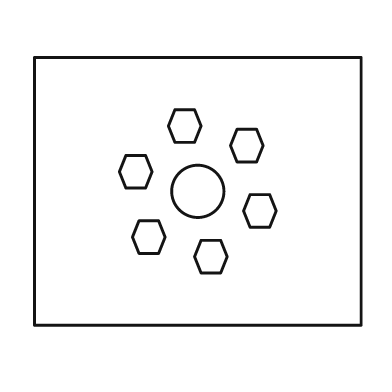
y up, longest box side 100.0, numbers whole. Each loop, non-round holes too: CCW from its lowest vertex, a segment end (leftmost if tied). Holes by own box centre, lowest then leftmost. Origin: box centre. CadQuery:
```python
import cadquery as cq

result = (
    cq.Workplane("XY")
    .moveTo(-50.0, -41.0)
    .lineTo(50.0, -41.0)
    .lineTo(50.0, 41.0)
    .lineTo(-50.0, 41.0)
    .close()
    .moveTo(1.0, -25.0)
    .lineTo(7.0, -25.0)
    .lineTo(9.0, -20.0)
    .lineTo(7.0, -15.0)
    .lineTo(1.0, -15.0)
    .lineTo(-1.0, -20.0)
    .close()
    .moveTo(-18.0, -19.0)
    .lineTo(-12.0, -19.0)
    .lineTo(-10.0, -14.0)
    .lineTo(-12.0, -9.0)
    .lineTo(-18.0, -9.0)
    .lineTo(-20.0, -14.0)
    .close()
    .moveTo(16.0, -11.0)
    .lineTo(22.0, -11.0)
    .lineTo(24.0, -6.0)
    .lineTo(22.0, -1.0)
    .lineTo(16.0, -1.0)
    .lineTo(14.0, -6.0)
    .close()
    .moveTo(0.0, 0.0)
    .circle(8.0)
    .moveTo(-22.0, 1.0)
    .lineTo(-16.0, 1.0)
    .lineTo(-14.0, 6.0)
    .lineTo(-16.0, 11.0)
    .lineTo(-22.0, 11.0)
    .lineTo(-24.0, 6.0)
    .close()
    .moveTo(12.0, 9.0)
    .lineTo(18.0, 9.0)
    .lineTo(20.0, 14.0)
    .lineTo(18.0, 19.0)
    .lineTo(12.0, 19.0)
    .lineTo(10.0, 14.0)
    .close()
    .moveTo(-7.0, 15.0)
    .lineTo(-1.0, 15.0)
    .lineTo(1.0, 20.0)
    .lineTo(-1.0, 25.0)
    .lineTo(-7.0, 25.0)
    .lineTo(-9.0, 20.0)
    .close()
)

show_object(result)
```